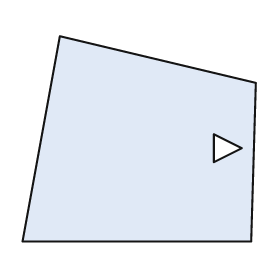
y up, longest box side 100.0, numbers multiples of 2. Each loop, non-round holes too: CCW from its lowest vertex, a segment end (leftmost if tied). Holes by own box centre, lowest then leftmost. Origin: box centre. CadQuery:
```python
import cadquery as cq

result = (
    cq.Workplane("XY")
    .moveTo(-50.0, -44.0)
    .lineTo(48.0, -44.0)
    .lineTo(50.0, 24.0)
    .lineTo(-34.0, 44.0)
    .close()
    .moveTo(32.0, -10.0)
    .lineTo(44.0, -4.0)
    .lineTo(32.0, 2.0)
    .close()
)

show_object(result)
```